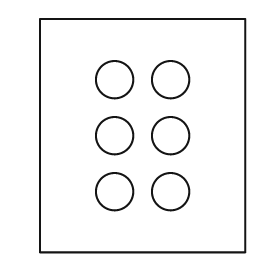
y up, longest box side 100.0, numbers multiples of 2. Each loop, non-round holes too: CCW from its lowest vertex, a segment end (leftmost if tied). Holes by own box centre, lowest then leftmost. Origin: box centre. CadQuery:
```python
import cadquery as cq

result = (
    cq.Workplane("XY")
    .moveTo(-44.0, -50.0)
    .lineTo(44.0, -50.0)
    .lineTo(44.0, 50.0)
    .lineTo(-44.0, 50.0)
    .close()
    .moveTo(-12.0, -24.0)
    .circle(8.0)
    .moveTo(12.0, -24.0)
    .circle(8.0)
    .moveTo(-12.0, 0.0)
    .circle(8.0)
    .moveTo(12.0, 0.0)
    .circle(8.0)
    .moveTo(-12.0, 24.0)
    .circle(8.0)
    .moveTo(12.0, 24.0)
    .circle(8.0)
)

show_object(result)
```